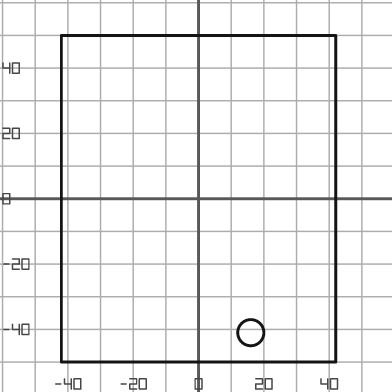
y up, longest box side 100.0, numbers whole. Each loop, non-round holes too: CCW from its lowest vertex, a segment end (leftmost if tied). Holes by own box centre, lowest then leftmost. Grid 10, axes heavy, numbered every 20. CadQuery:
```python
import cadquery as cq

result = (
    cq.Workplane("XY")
    .moveTo(-42.0, -50.0)
    .lineTo(42.0, -50.0)
    .lineTo(42.0, 50.0)
    .lineTo(-42.0, 50.0)
    .close()
    .moveTo(16.0, -41.0)
    .circle(4.0)
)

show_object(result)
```